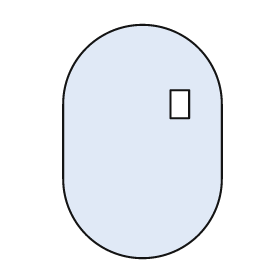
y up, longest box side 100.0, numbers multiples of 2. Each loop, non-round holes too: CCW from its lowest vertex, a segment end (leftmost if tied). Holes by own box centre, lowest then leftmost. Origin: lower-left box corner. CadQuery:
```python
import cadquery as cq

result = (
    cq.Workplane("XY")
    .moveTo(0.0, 34.0)
    .threePointArc((34.0, 0.0), (68.0, 34.0))
    .lineTo(68.0, 66.0)
    .threePointArc((34.0, 100.0), (0.0, 66.0))
    .close()
    .moveTo(46.0, 60.0)
    .lineTo(54.0, 60.0)
    .lineTo(54.0, 72.0)
    .lineTo(46.0, 72.0)
    .close()
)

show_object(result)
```